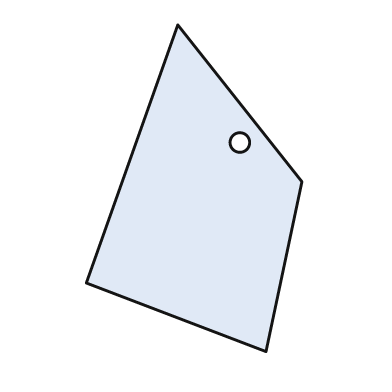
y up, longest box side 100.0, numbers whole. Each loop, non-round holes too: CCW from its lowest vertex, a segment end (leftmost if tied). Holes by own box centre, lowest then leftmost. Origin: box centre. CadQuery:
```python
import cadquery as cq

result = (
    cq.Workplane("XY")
    .moveTo(22.0, -50.0)
    .lineTo(33.0, 2.0)
    .lineTo(-5.0, 50.0)
    .lineTo(-33.0, -29.0)
    .close()
    .moveTo(14.0, 14.0)
    .circle(3.0)
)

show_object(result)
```